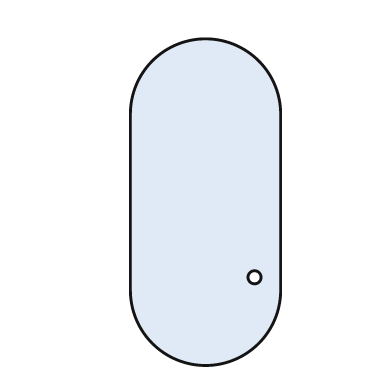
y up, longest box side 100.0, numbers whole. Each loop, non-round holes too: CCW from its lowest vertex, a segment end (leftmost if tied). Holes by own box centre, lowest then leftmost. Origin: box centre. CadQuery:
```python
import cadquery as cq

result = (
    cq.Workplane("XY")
    .moveTo(-23.0, -27.0)
    .threePointArc((0.0, -50.0), (23.0, -27.0))
    .lineTo(23.0, 27.0)
    .threePointArc((0.0, 50.0), (-23.0, 27.0))
    .close()
    .moveTo(15.0, -23.0)
    .circle(2.0)
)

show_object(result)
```